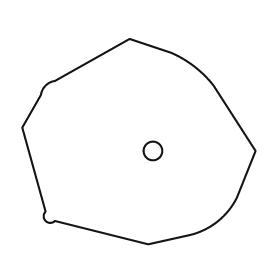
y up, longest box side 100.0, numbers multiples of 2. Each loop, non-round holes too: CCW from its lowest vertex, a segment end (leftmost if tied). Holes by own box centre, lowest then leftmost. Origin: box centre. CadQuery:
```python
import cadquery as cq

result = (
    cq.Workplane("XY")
    .moveTo(4.0, -44.0)
    .lineTo(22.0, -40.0)
    .threePointArc((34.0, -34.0), (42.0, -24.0))
    .lineTo(50.0, -4.0)
    .lineTo(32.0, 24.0)
    .threePointArc((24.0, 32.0), (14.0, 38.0))
    .lineTo(-4.0, 44.0)
    .lineTo(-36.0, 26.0)
    .threePointArc((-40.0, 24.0), (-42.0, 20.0))
    .lineTo(-50.0, 6.0)
    .lineTo(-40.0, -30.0)
    .threePointArc((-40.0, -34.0), (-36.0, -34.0))
    .close()
    .moveTo(6.0, -4.0)
    .circle(4.0)
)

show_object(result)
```